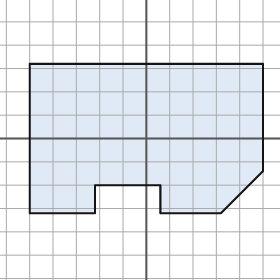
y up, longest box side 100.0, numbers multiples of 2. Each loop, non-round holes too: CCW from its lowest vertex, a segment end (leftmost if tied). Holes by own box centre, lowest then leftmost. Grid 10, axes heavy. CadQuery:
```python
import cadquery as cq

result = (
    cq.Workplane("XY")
    .moveTo(-50.0, -32.0)
    .lineTo(-22.0, -32.0)
    .lineTo(-22.0, -20.0)
    .lineTo(6.0, -20.0)
    .lineTo(6.0, -32.0)
    .lineTo(32.0, -32.0)
    .lineTo(50.0, -14.0)
    .lineTo(50.0, 32.0)
    .lineTo(-50.0, 32.0)
    .close()
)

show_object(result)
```